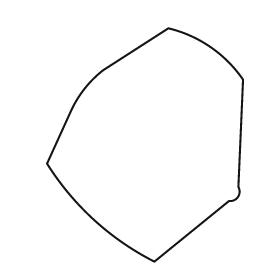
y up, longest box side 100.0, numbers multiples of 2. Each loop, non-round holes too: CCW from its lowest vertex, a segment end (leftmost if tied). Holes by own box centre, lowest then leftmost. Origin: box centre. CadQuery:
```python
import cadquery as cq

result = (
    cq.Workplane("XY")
    .moveTo(4.0, -50.0)
    .lineTo(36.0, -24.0)
    .threePointArc((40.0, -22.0), (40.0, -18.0))
    .lineTo(42.0, 28.0)
    .threePointArc((28.0, 42.0), (10.0, 50.0))
    .lineTo(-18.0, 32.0)
    .threePointArc((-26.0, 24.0), (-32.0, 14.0))
    .lineTo(-42.0, -8.0)
    .threePointArc((-22.0, -32.0), (4.0, -50.0))
    .close()
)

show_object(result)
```